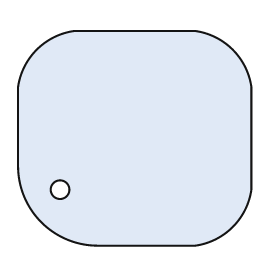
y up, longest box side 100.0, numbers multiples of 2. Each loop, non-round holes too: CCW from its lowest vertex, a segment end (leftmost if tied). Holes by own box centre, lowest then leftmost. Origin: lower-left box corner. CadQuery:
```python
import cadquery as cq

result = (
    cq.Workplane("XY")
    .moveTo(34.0, 0.0)
    .lineTo(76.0, 0.0)
    .threePointArc((92.0, 8.0), (100.0, 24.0))
    .lineTo(100.0, 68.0)
    .threePointArc((92.0, 84.0), (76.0, 92.0))
    .lineTo(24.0, 92.0)
    .threePointArc((8.0, 84.0), (0.0, 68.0))
    .lineTo(0.0, 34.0)
    .threePointArc((10.0, 10.0), (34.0, 0.0))
    .close()
    .moveTo(18.0, 24.0)
    .circle(4.0)
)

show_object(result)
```